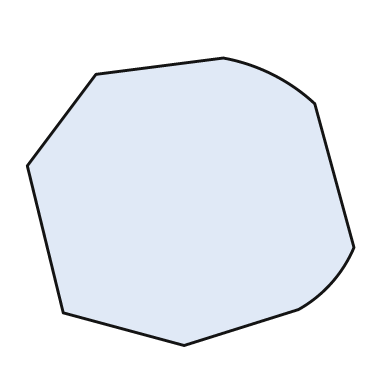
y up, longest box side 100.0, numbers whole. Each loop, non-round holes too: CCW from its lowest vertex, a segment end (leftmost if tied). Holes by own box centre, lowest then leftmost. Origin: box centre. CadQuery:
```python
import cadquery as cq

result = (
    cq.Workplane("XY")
    .moveTo(-2.0, -44.0)
    .lineTo(33.0, -33.0)
    .threePointArc((43.0, -25.0), (50.0, -14.0))
    .lineTo(38.0, 30.0)
    .threePointArc((25.0, 39.0), (10.0, 44.0))
    .lineTo(-29.0, 39.0)
    .lineTo(-50.0, 11.0)
    .lineTo(-39.0, -34.0)
    .close()
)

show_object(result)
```